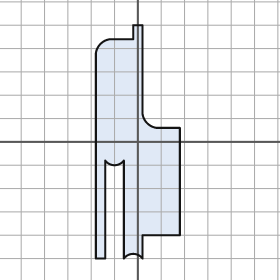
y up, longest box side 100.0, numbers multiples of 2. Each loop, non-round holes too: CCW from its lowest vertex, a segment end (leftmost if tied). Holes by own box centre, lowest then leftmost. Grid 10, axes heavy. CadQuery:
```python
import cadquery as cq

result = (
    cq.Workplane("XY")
    .moveTo(-18.0, -50.0)
    .lineTo(-14.0, -50.0)
    .lineTo(-14.0, -8.0)
    .threePointArc((-10.0, -10.0), (-6.0, -8.0))
    .lineTo(-6.0, -50.0)
    .threePointArc((-2.0, -48.0), (2.0, -50.0))
    .lineTo(2.0, -40.0)
    .lineTo(18.0, -40.0)
    .lineTo(18.0, 6.0)
    .lineTo(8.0, 6.0)
    .threePointArc((4.0, 8.0), (2.0, 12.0))
    .lineTo(2.0, 50.0)
    .lineTo(-2.0, 50.0)
    .lineTo(-2.0, 44.0)
    .lineTo(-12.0, 44.0)
    .threePointArc((-16.0, 42.0), (-18.0, 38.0))
    .close()
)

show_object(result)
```